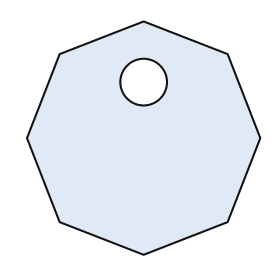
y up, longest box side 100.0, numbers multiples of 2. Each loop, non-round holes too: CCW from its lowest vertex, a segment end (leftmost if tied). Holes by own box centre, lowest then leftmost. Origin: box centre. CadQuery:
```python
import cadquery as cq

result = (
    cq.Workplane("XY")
    .moveTo(0.0, -50.0)
    .lineTo(36.0, -36.0)
    .lineTo(50.0, 0.0)
    .lineTo(36.0, 36.0)
    .lineTo(0.0, 50.0)
    .lineTo(-36.0, 36.0)
    .lineTo(-50.0, 0.0)
    .lineTo(-36.0, -36.0)
    .close()
    .moveTo(0.0, 24.0)
    .circle(10.0)
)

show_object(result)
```